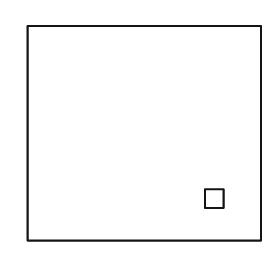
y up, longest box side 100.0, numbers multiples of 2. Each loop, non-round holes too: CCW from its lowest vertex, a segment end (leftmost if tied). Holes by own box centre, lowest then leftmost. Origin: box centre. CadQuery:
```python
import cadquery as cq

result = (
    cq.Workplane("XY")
    .moveTo(-50.0, -46.0)
    .lineTo(50.0, -46.0)
    .lineTo(50.0, 46.0)
    .lineTo(-50.0, 46.0)
    .close()
    .moveTo(26.0, -32.0)
    .lineTo(34.0, -32.0)
    .lineTo(34.0, -24.0)
    .lineTo(26.0, -24.0)
    .close()
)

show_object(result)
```